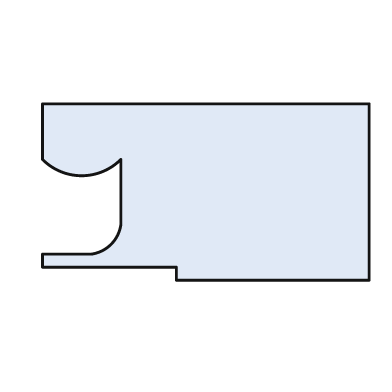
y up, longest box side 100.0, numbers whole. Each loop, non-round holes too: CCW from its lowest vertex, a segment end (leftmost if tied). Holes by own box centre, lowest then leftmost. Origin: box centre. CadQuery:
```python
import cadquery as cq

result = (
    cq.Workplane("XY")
    .moveTo(-9.0, -27.0)
    .lineTo(50.0, -27.0)
    .lineTo(50.0, 27.0)
    .lineTo(-50.0, 27.0)
    .lineTo(-50.0, 10.0)
    .threePointArc((-38.0, 5.0), (-26.0, 10.0))
    .lineTo(-26.0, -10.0)
    .threePointArc((-29.0, -16.0), (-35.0, -19.0))
    .lineTo(-50.0, -19.0)
    .lineTo(-50.0, -23.0)
    .lineTo(-9.0, -23.0)
    .close()
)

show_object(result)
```